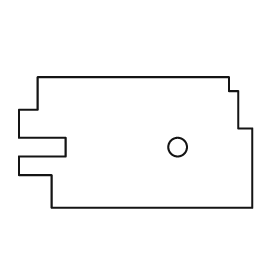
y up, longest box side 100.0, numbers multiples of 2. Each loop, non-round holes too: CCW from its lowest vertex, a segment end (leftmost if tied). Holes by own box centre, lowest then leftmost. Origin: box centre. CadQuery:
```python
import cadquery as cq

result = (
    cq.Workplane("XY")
    .moveTo(-36.0, -28.0)
    .lineTo(50.0, -28.0)
    .lineTo(50.0, 6.0)
    .lineTo(44.0, 6.0)
    .lineTo(44.0, 22.0)
    .lineTo(40.0, 22.0)
    .lineTo(40.0, 28.0)
    .lineTo(-42.0, 28.0)
    .lineTo(-42.0, 14.0)
    .lineTo(-50.0, 14.0)
    .lineTo(-50.0, 2.0)
    .lineTo(-30.0, 2.0)
    .lineTo(-30.0, -6.0)
    .lineTo(-50.0, -6.0)
    .lineTo(-50.0, -14.0)
    .lineTo(-36.0, -14.0)
    .close()
    .moveTo(18.0, -2.0)
    .circle(4.0)
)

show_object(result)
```